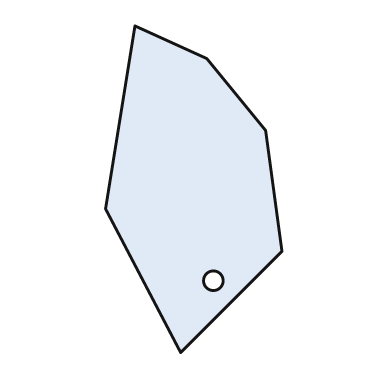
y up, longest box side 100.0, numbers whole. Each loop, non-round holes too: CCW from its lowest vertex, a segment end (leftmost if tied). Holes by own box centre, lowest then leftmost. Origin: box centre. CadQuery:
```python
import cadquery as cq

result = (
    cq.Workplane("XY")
    .moveTo(-4.0, -50.0)
    .lineTo(27.0, -19.0)
    .lineTo(22.0, 18.0)
    .lineTo(4.0, 40.0)
    .lineTo(-18.0, 50.0)
    .lineTo(-27.0, -6.0)
    .close()
    .moveTo(6.0, -28.0)
    .circle(3.0)
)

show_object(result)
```